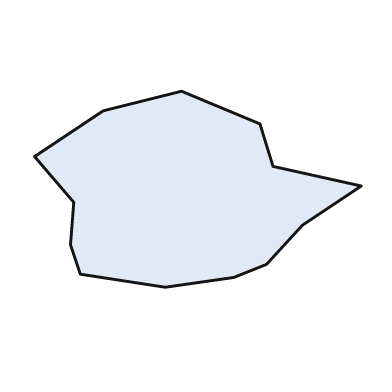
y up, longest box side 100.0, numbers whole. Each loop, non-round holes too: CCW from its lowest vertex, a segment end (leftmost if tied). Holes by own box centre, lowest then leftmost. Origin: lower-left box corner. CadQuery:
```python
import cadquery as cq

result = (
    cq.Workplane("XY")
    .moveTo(40.0, 0.0)
    .lineTo(61.0, 3.0)
    .lineTo(71.0, 7.0)
    .lineTo(82.0, 19.0)
    .lineTo(100.0, 31.0)
    .lineTo(73.0, 37.0)
    .lineTo(69.0, 50.0)
    .lineTo(45.0, 60.0)
    .lineTo(21.0, 54.0)
    .lineTo(0.0, 40.0)
    .lineTo(12.0, 26.0)
    .lineTo(11.0, 13.0)
    .lineTo(14.0, 4.0)
    .close()
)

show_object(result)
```